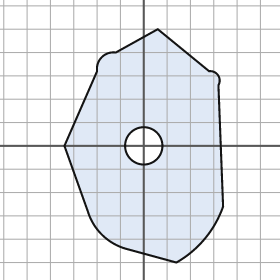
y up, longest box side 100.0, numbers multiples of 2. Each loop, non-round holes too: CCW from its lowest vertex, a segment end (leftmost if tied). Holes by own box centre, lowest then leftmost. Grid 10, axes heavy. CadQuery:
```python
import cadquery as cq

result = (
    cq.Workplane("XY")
    .moveTo(14.0, -50.0)
    .threePointArc((26.0, -40.0), (34.0, -26.0))
    .lineTo(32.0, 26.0)
    .threePointArc((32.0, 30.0), (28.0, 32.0))
    .lineTo(6.0, 50.0)
    .lineTo(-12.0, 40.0)
    .threePointArc((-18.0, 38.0), (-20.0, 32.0))
    .lineTo(-34.0, 0.0)
    .lineTo(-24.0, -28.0)
    .threePointArc((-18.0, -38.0), (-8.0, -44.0))
    .close()
    .moveTo(0.0, 0.0)
    .circle(8.0)
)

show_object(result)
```